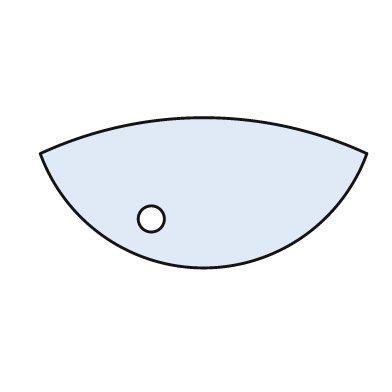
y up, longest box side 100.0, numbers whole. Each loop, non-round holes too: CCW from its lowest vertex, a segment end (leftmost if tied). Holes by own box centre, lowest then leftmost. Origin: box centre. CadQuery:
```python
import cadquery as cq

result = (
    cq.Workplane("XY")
    .moveTo(-50.0, 12.0)
    .threePointArc((0.0, -23.0), (50.0, 12.0))
    .threePointArc((0.0, 23.0), (-50.0, 12.0))
    .close()
    .moveTo(-16.0, -8.0)
    .circle(4.0)
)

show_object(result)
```